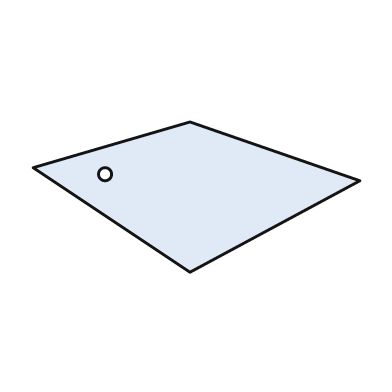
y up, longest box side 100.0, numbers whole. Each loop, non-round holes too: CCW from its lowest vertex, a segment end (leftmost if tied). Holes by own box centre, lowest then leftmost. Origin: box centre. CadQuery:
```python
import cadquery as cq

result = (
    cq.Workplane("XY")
    .moveTo(-2.0, -23.0)
    .lineTo(50.0, 5.0)
    .lineTo(-2.0, 23.0)
    .lineTo(-50.0, 9.0)
    .close()
    .moveTo(-28.0, 7.0)
    .circle(2.0)
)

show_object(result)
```